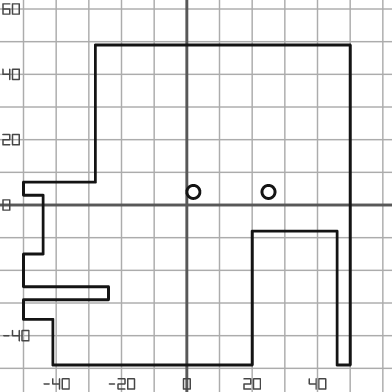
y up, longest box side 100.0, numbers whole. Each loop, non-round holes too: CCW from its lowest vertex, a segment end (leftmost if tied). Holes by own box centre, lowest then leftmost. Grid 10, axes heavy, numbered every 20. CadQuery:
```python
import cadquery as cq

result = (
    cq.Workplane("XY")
    .moveTo(-41.0, -49.0)
    .lineTo(20.0, -49.0)
    .lineTo(20.0, -8.0)
    .lineTo(46.0, -8.0)
    .lineTo(46.0, -49.0)
    .lineTo(50.0, -49.0)
    .lineTo(50.0, 49.0)
    .lineTo(-28.0, 49.0)
    .lineTo(-28.0, 7.0)
    .lineTo(-50.0, 7.0)
    .lineTo(-50.0, 3.0)
    .lineTo(-44.0, 3.0)
    .lineTo(-44.0, -15.0)
    .lineTo(-50.0, -15.0)
    .lineTo(-50.0, -25.0)
    .lineTo(-24.0, -25.0)
    .lineTo(-24.0, -29.0)
    .lineTo(-50.0, -29.0)
    .lineTo(-50.0, -35.0)
    .lineTo(-41.0, -35.0)
    .close()
    .moveTo(2.0, 4.0)
    .circle(2.0)
    .moveTo(25.0, 4.0)
    .circle(2.0)
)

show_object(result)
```